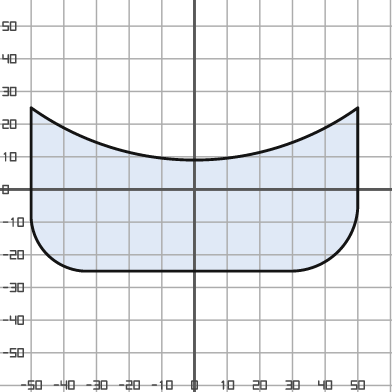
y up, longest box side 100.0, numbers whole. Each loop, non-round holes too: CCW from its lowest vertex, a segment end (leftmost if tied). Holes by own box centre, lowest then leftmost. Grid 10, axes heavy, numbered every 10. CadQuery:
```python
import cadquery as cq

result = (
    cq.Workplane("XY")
    .moveTo(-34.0, -25.0)
    .lineTo(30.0, -25.0)
    .threePointArc((44.0, -19.0), (50.0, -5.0))
    .lineTo(50.0, 25.0)
    .threePointArc((0.0, 9.0), (-50.0, 25.0))
    .lineTo(-50.0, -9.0)
    .threePointArc((-45.0, -20.0), (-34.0, -25.0))
    .close()
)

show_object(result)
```